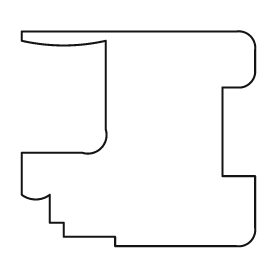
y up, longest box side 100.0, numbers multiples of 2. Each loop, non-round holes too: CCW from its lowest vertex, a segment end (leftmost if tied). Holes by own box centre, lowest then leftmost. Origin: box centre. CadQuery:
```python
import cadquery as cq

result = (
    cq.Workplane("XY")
    .moveTo(-10.0, -46.0)
    .lineTo(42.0, -46.0)
    .threePointArc((48.0, -44.0), (50.0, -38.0))
    .lineTo(50.0, -16.0)
    .lineTo(36.0, -16.0)
    .lineTo(36.0, 22.0)
    .lineTo(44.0, 22.0)
    .threePointArc((48.0, 24.0), (50.0, 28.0))
    .lineTo(50.0, 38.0)
    .threePointArc((48.0, 44.0), (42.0, 46.0))
    .lineTo(-50.0, 46.0)
    .lineTo(-50.0, 42.0)
    .threePointArc((-32.0, 40.0), (-14.0, 42.0))
    .lineTo(-14.0, 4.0)
    .threePointArc((-16.0, -4.0), (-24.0, -6.0))
    .lineTo(-50.0, -6.0)
    .lineTo(-50.0, -24.0)
    .threePointArc((-44.0, -26.0), (-38.0, -24.0))
    .lineTo(-38.0, -36.0)
    .lineTo(-32.0, -36.0)
    .lineTo(-32.0, -42.0)
    .lineTo(-10.0, -42.0)
    .close()
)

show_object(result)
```